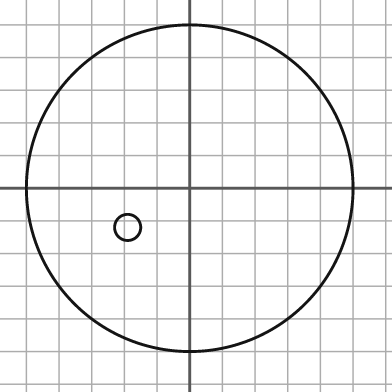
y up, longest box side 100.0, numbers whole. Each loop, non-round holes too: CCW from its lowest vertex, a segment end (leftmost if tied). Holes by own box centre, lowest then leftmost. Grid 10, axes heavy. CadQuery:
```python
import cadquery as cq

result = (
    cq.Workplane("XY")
    .moveTo(0.0, 0.0)
    .circle(50.0)
    .moveTo(-19.0, -12.0)
    .circle(4.0)
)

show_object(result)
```